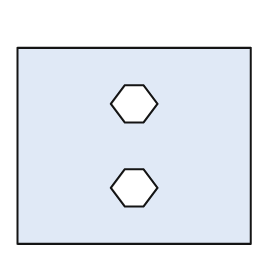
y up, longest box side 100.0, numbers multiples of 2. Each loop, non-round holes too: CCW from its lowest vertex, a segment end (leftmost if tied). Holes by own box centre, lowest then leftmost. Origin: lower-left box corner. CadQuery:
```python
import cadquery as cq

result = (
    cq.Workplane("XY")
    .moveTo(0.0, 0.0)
    .lineTo(100.0, 0.0)
    .lineTo(100.0, 84.0)
    .lineTo(0.0, 84.0)
    .close()
    .moveTo(46.0, 16.0)
    .lineTo(54.0, 16.0)
    .lineTo(60.0, 24.0)
    .lineTo(54.0, 32.0)
    .lineTo(46.0, 32.0)
    .lineTo(40.0, 24.0)
    .close()
    .moveTo(46.0, 52.0)
    .lineTo(54.0, 52.0)
    .lineTo(60.0, 60.0)
    .lineTo(54.0, 68.0)
    .lineTo(46.0, 68.0)
    .lineTo(40.0, 60.0)
    .close()
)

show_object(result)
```